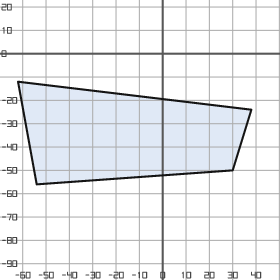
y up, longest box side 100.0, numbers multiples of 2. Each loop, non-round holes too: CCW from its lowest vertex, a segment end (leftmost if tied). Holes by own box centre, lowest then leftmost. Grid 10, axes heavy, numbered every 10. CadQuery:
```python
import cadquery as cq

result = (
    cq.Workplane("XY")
    .moveTo(-54.0, -56.0)
    .lineTo(30.0, -50.0)
    .lineTo(38.0, -24.0)
    .lineTo(-62.0, -12.0)
    .close()
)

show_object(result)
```